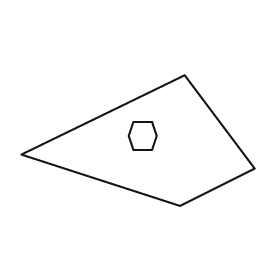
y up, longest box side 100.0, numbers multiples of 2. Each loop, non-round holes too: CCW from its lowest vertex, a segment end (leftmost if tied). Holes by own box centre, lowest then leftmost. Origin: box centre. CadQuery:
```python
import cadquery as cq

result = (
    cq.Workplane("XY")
    .moveTo(18.0, -28.0)
    .lineTo(50.0, -12.0)
    .lineTo(20.0, 28.0)
    .lineTo(-50.0, -6.0)
    .close()
    .moveTo(-2.0, -4.0)
    .lineTo(6.0, -4.0)
    .lineTo(8.0, 2.0)
    .lineTo(6.0, 8.0)
    .lineTo(-2.0, 8.0)
    .lineTo(-4.0, 2.0)
    .close()
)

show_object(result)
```